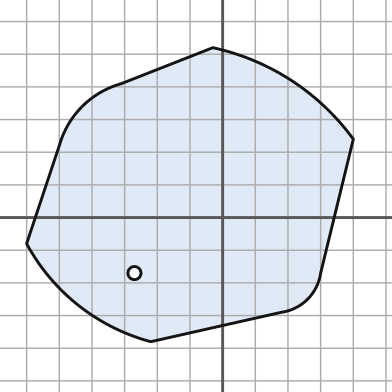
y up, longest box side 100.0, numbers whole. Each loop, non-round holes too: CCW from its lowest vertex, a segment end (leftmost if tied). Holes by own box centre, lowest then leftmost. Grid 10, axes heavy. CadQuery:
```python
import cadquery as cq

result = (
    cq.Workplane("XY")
    .moveTo(-22.0, -38.0)
    .lineTo(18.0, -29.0)
    .threePointArc((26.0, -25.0), (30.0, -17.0))
    .lineTo(40.0, 24.0)
    .threePointArc((21.0, 42.0), (-3.0, 52.0))
    .lineTo(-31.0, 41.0)
    .threePointArc((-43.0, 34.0), (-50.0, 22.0))
    .lineTo(-60.0, -8.0)
    .threePointArc((-44.0, -27.0), (-22.0, -38.0))
    .close()
    .moveTo(-27.0, -17.0)
    .circle(2.0)
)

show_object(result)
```